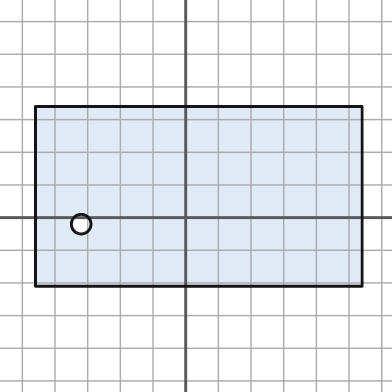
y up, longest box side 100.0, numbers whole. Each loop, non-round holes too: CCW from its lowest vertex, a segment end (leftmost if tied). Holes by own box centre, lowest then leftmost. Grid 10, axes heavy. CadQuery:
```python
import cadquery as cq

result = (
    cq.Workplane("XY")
    .moveTo(-46.0, -21.0)
    .lineTo(54.0, -21.0)
    .lineTo(54.0, 34.0)
    .lineTo(-46.0, 34.0)
    .close()
    .moveTo(-32.0, -2.0)
    .circle(3.0)
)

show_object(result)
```